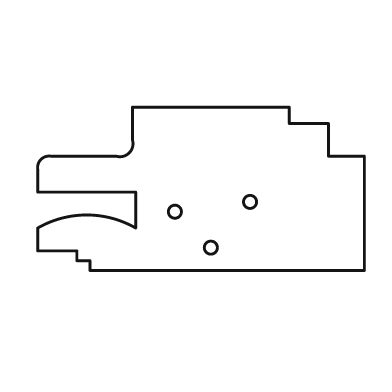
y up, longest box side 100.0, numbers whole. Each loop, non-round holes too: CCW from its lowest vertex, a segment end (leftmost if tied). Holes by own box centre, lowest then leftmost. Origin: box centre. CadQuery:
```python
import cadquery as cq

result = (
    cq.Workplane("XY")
    .moveTo(-34.0, -25.0)
    .lineTo(50.0, -25.0)
    .lineTo(50.0, 10.0)
    .lineTo(39.0, 10.0)
    .lineTo(39.0, 20.0)
    .lineTo(27.0, 20.0)
    .lineTo(27.0, 25.0)
    .lineTo(-21.0, 25.0)
    .lineTo(-21.0, 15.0)
    .threePointArc((-22.0, 11.0), (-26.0, 10.0))
    .lineTo(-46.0, 10.0)
    .threePointArc((-49.0, 9.0), (-50.0, 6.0))
    .lineTo(-50.0, -1.0)
    .lineTo(-20.0, -1.0)
    .lineTo(-20.0, -12.0)
    .threePointArc((-35.0, -8.0), (-50.0, -12.0))
    .lineTo(-50.0, -19.0)
    .lineTo(-38.0, -19.0)
    .lineTo(-38.0, -22.0)
    .lineTo(-34.0, -22.0)
    .close()
    .moveTo(3.0, -18.0)
    .circle(2.0)
    .moveTo(-8.0, -7.0)
    .circle(2.0)
    .moveTo(15.0, -4.0)
    .circle(2.0)
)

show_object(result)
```